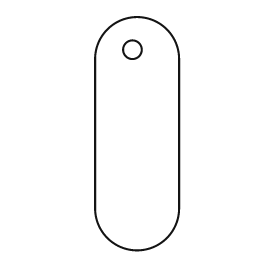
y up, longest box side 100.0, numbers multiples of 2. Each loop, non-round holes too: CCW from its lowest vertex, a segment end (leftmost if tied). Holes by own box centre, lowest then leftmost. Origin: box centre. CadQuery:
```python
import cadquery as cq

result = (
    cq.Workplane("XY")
    .moveTo(-18.0, -32.0)
    .threePointArc((0.0, -50.0), (18.0, -32.0))
    .lineTo(18.0, 32.0)
    .threePointArc((0.0, 50.0), (-18.0, 32.0))
    .close()
    .moveTo(-2.0, 36.0)
    .circle(4.0)
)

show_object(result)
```